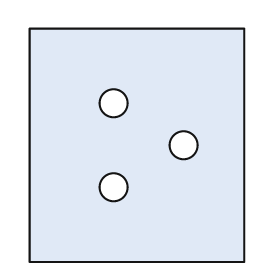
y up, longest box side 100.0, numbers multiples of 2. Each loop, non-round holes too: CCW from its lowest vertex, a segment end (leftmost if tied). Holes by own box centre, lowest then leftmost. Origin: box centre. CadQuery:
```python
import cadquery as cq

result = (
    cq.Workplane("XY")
    .moveTo(-46.0, -50.0)
    .lineTo(46.0, -50.0)
    .lineTo(46.0, 50.0)
    .lineTo(-46.0, 50.0)
    .close()
    .moveTo(-10.0, -18.0)
    .circle(6.0)
    .moveTo(20.0, 0.0)
    .circle(6.0)
    .moveTo(-10.0, 18.0)
    .circle(6.0)
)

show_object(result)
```